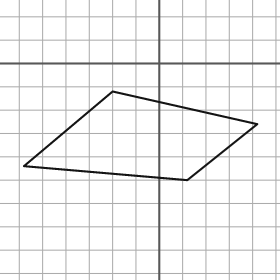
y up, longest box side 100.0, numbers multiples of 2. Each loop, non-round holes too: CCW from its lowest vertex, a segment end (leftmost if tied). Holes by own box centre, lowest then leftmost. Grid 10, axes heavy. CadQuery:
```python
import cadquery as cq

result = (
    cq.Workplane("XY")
    .moveTo(12.0, -50.0)
    .lineTo(42.0, -26.0)
    .lineTo(-20.0, -12.0)
    .lineTo(-58.0, -44.0)
    .close()
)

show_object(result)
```